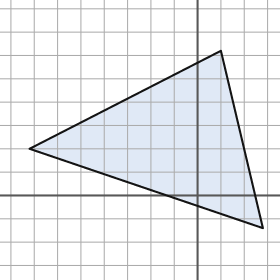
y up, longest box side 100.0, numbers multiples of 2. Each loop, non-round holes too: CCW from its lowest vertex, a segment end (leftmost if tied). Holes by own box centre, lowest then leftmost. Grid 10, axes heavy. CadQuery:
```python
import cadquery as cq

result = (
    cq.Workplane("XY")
    .moveTo(28.0, -14.0)
    .lineTo(10.0, 62.0)
    .lineTo(-72.0, 20.0)
    .close()
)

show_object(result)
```